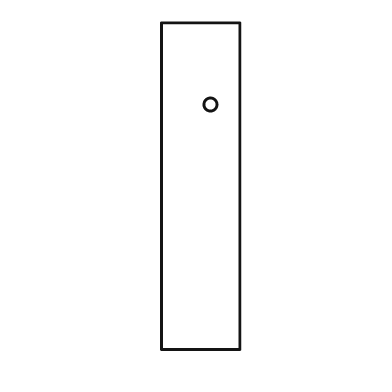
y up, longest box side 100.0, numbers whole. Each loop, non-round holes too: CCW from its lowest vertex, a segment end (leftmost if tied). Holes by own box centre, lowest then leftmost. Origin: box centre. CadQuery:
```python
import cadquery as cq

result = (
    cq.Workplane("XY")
    .moveTo(-12.0, -50.0)
    .lineTo(12.0, -50.0)
    .lineTo(12.0, 50.0)
    .lineTo(-12.0, 50.0)
    .close()
    .moveTo(3.0, 25.0)
    .circle(2.0)
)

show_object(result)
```